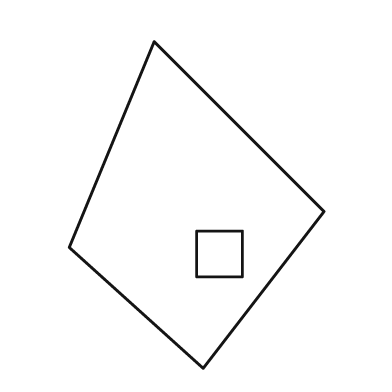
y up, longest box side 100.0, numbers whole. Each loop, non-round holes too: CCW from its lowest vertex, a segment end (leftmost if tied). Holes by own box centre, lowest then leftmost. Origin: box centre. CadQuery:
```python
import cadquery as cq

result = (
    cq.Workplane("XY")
    .moveTo(2.0, -50.0)
    .lineTo(39.0, -2.0)
    .lineTo(-13.0, 50.0)
    .lineTo(-39.0, -13.0)
    .close()
    .moveTo(0.0, -22.0)
    .lineTo(14.0, -22.0)
    .lineTo(14.0, -8.0)
    .lineTo(0.0, -8.0)
    .close()
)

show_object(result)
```